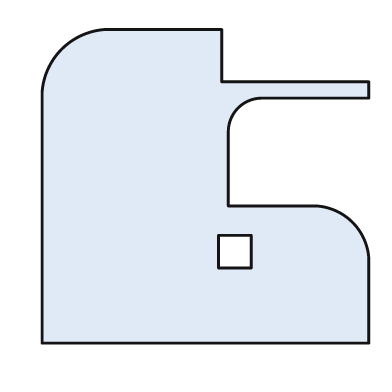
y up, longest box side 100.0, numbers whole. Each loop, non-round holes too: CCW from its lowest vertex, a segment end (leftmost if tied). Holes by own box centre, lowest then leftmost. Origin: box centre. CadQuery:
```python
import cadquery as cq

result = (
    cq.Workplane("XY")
    .moveTo(-50.0, -48.0)
    .lineTo(50.0, -48.0)
    .lineTo(50.0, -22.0)
    .threePointArc((45.0, -11.0), (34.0, -6.0))
    .lineTo(7.0, -6.0)
    .lineTo(7.0, 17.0)
    .threePointArc((10.0, 24.0), (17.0, 27.0))
    .lineTo(50.0, 27.0)
    .lineTo(50.0, 32.0)
    .lineTo(5.0, 32.0)
    .lineTo(5.0, 48.0)
    .lineTo(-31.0, 48.0)
    .threePointArc((-44.0, 42.0), (-50.0, 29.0))
    .close()
    .moveTo(4.0, -25.0)
    .lineTo(14.0, -25.0)
    .lineTo(14.0, -15.0)
    .lineTo(4.0, -15.0)
    .close()
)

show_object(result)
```